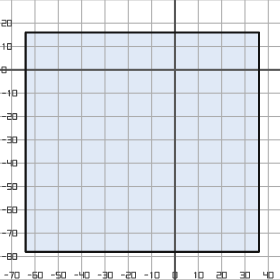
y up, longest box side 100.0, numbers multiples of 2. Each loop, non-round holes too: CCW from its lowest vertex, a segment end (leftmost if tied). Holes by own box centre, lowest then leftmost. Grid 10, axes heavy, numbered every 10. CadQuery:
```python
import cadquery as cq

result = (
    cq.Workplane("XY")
    .moveTo(-64.0, -78.0)
    .lineTo(36.0, -78.0)
    .lineTo(36.0, 16.0)
    .lineTo(-64.0, 16.0)
    .close()
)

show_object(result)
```